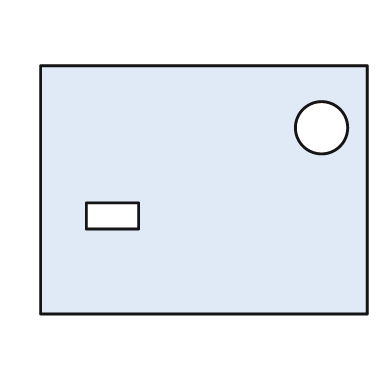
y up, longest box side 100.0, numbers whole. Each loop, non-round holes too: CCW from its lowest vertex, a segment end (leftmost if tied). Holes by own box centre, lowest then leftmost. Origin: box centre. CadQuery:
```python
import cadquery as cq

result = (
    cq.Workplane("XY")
    .moveTo(-50.0, -38.0)
    .lineTo(50.0, -38.0)
    .lineTo(50.0, 38.0)
    .lineTo(-50.0, 38.0)
    .close()
    .moveTo(-36.0, -12.0)
    .lineTo(-20.0, -12.0)
    .lineTo(-20.0, -4.0)
    .lineTo(-36.0, -4.0)
    .close()
    .moveTo(36.0, 19.0)
    .circle(8.0)
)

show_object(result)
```